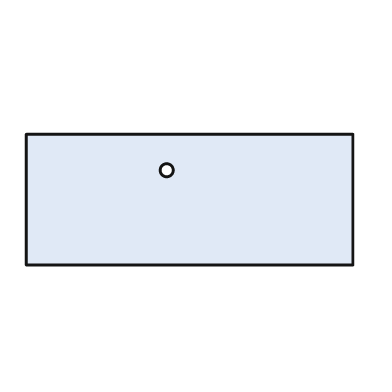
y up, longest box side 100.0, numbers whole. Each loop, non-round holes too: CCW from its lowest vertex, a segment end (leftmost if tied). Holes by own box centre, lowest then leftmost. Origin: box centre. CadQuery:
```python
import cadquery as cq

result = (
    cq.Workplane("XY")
    .moveTo(-50.0, -20.0)
    .lineTo(50.0, -20.0)
    .lineTo(50.0, 20.0)
    .lineTo(-50.0, 20.0)
    .close()
    .moveTo(-7.0, 9.0)
    .circle(2.0)
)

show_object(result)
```